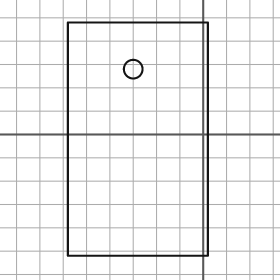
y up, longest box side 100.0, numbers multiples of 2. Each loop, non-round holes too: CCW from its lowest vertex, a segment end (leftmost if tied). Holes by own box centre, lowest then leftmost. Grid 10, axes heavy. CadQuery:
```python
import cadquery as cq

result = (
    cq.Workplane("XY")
    .moveTo(-58.0, -52.0)
    .lineTo(2.0, -52.0)
    .lineTo(2.0, 48.0)
    .lineTo(-58.0, 48.0)
    .close()
    .moveTo(-30.0, 28.0)
    .circle(4.0)
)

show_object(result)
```